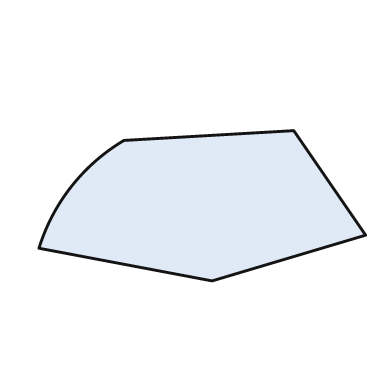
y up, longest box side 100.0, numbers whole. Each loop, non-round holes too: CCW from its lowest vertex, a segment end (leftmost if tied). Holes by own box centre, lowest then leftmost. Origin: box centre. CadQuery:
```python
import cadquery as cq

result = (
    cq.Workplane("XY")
    .moveTo(3.0, -23.0)
    .lineTo(50.0, -9.0)
    .lineTo(28.0, 23.0)
    .lineTo(-24.0, 20.0)
    .threePointArc((-40.0, 6.0), (-50.0, -13.0))
    .close()
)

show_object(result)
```